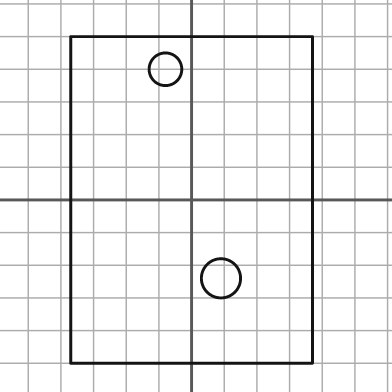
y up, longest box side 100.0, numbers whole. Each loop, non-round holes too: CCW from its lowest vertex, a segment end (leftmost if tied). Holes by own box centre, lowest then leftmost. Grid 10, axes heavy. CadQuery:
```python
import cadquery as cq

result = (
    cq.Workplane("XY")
    .moveTo(-37.0, -50.0)
    .lineTo(37.0, -50.0)
    .lineTo(37.0, 50.0)
    .lineTo(-37.0, 50.0)
    .close()
    .moveTo(9.0, -24.0)
    .circle(6.0)
    .moveTo(-8.0, 40.0)
    .circle(5.0)
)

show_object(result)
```